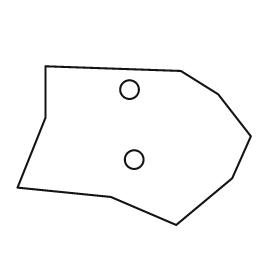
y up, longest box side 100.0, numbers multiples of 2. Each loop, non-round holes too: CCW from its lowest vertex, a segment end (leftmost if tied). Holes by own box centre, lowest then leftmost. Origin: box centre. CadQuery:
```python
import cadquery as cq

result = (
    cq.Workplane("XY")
    .moveTo(18.0, -34.0)
    .lineTo(42.0, -14.0)
    .lineTo(50.0, 4.0)
    .lineTo(36.0, 22.0)
    .lineTo(20.0, 32.0)
    .lineTo(-38.0, 34.0)
    .lineTo(-38.0, 12.0)
    .lineTo(-50.0, -18.0)
    .lineTo(-10.0, -22.0)
    .close()
    .moveTo(0.0, -6.0)
    .circle(4.0)
    .moveTo(-2.0, 24.0)
    .circle(4.0)
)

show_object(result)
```